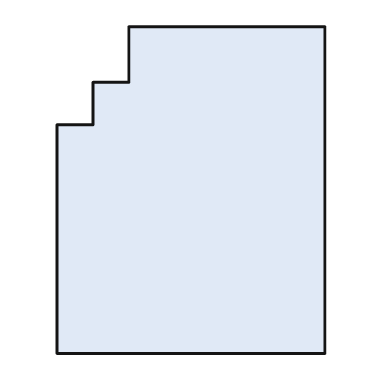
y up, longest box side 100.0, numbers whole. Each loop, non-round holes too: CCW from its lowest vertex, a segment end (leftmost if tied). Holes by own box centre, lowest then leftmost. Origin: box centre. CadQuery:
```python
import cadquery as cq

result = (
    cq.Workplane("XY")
    .moveTo(-41.0, -50.0)
    .lineTo(41.0, -50.0)
    .lineTo(41.0, 50.0)
    .lineTo(-19.0, 50.0)
    .lineTo(-19.0, 33.0)
    .lineTo(-30.0, 33.0)
    .lineTo(-30.0, 20.0)
    .lineTo(-41.0, 20.0)
    .close()
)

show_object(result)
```